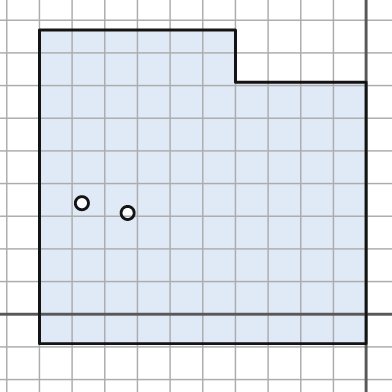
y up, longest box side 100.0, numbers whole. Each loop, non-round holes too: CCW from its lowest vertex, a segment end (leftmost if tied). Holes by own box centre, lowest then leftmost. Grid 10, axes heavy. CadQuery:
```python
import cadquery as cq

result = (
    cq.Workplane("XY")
    .moveTo(-100.0, -9.0)
    .lineTo(0.0, -9.0)
    .lineTo(0.0, 71.0)
    .lineTo(-40.0, 71.0)
    .lineTo(-40.0, 87.0)
    .lineTo(-100.0, 87.0)
    .close()
    .moveTo(-73.0, 31.0)
    .circle(2.0)
    .moveTo(-87.0, 34.0)
    .circle(2.0)
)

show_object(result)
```